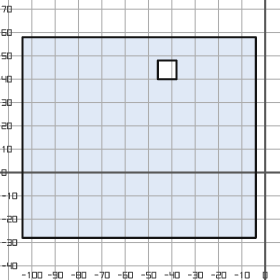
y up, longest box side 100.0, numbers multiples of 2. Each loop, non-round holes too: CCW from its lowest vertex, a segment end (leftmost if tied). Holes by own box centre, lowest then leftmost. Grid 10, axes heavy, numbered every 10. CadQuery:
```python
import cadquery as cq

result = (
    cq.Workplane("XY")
    .moveTo(-104.0, -28.0)
    .lineTo(-4.0, -28.0)
    .lineTo(-4.0, 58.0)
    .lineTo(-104.0, 58.0)
    .close()
    .moveTo(-46.0, 40.0)
    .lineTo(-38.0, 40.0)
    .lineTo(-38.0, 48.0)
    .lineTo(-46.0, 48.0)
    .close()
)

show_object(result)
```